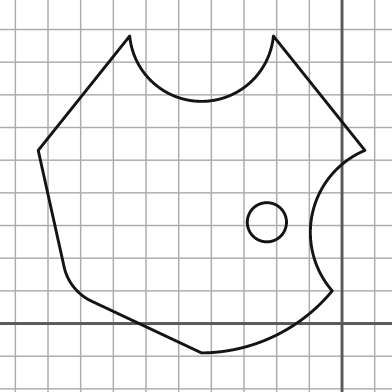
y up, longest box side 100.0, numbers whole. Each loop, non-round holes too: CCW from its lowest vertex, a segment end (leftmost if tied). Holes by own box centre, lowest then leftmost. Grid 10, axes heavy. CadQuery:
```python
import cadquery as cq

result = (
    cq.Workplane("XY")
    .moveTo(-43.0, -9.0)
    .threePointArc((-21.0, -4.0), (-3.0, 10.0))
    .threePointArc((-9.0, 34.0), (7.0, 53.0))
    .lineTo(-21.0, 88.0)
    .threePointArc((-43.0, 68.0), (-65.0, 88.0))
    .lineTo(-93.0, 53.0)
    .lineTo(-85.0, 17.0)
    .threePointArc((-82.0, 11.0), (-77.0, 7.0))
    .close()
    .moveTo(-23.0, 31.0)
    .circle(6.0)
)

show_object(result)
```